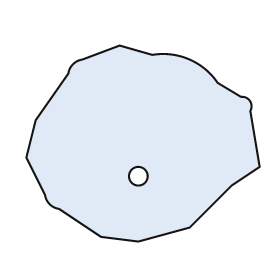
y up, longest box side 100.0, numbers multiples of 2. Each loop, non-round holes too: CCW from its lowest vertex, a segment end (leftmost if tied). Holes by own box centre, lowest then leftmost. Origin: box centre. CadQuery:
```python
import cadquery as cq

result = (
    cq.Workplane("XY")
    .moveTo(-2.0, -42.0)
    .lineTo(20.0, -36.0)
    .lineTo(38.0, -18.0)
    .lineTo(50.0, -10.0)
    .lineTo(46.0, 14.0)
    .threePointArc((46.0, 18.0), (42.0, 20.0))
    .lineTo(32.0, 26.0)
    .threePointArc((20.0, 36.0), (4.0, 38.0))
    .lineTo(-10.0, 42.0)
    .lineTo(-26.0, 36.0)
    .threePointArc((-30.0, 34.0), (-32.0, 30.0))
    .lineTo(-46.0, 10.0)
    .lineTo(-50.0, -6.0)
    .lineTo(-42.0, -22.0)
    .threePointArc((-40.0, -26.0), (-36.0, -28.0))
    .lineTo(-18.0, -40.0)
    .close()
    .moveTo(-2.0, -14.0)
    .circle(4.0)
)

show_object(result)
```